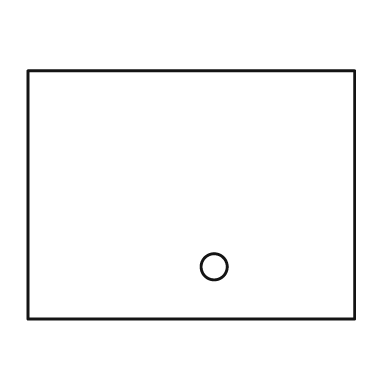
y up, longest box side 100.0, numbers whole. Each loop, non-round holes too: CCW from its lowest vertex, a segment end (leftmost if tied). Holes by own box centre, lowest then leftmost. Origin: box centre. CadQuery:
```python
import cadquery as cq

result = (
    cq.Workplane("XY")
    .moveTo(-50.0, -38.0)
    .lineTo(50.0, -38.0)
    .lineTo(50.0, 38.0)
    .lineTo(-50.0, 38.0)
    .close()
    .moveTo(7.0, -22.0)
    .circle(4.0)
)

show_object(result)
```